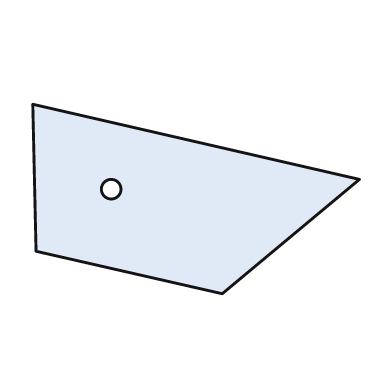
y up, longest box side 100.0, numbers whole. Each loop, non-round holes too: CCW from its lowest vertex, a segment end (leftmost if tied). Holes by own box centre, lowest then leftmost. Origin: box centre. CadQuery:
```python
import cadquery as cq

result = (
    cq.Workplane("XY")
    .moveTo(8.0, -29.0)
    .lineTo(50.0, 6.0)
    .lineTo(-50.0, 29.0)
    .lineTo(-49.0, -16.0)
    .close()
    .moveTo(-26.0, 3.0)
    .circle(3.0)
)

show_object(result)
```